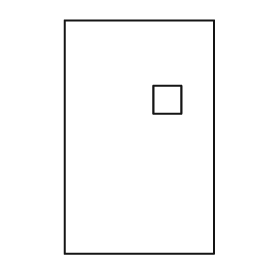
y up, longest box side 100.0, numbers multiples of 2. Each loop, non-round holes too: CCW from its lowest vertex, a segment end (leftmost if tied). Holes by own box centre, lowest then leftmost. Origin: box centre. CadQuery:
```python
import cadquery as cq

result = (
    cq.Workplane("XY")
    .moveTo(-32.0, -50.0)
    .lineTo(32.0, -50.0)
    .lineTo(32.0, 50.0)
    .lineTo(-32.0, 50.0)
    .close()
    .moveTo(6.0, 10.0)
    .lineTo(18.0, 10.0)
    .lineTo(18.0, 22.0)
    .lineTo(6.0, 22.0)
    .close()
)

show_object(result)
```